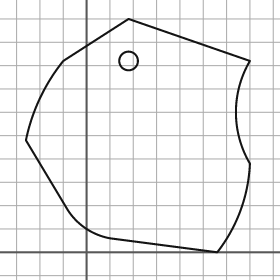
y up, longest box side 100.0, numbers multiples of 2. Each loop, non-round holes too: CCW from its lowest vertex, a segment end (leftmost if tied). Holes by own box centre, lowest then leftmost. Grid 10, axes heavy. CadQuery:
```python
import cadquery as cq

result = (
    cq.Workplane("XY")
    .moveTo(56.0, 0.0)
    .threePointArc((66.0, 18.0), (70.0, 38.0))
    .threePointArc((64.0, 60.0), (70.0, 82.0))
    .lineTo(18.0, 100.0)
    .lineTo(-10.0, 82.0)
    .threePointArc((-20.0, 66.0), (-26.0, 48.0))
    .lineTo(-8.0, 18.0)
    .threePointArc((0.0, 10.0), (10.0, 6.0))
    .close()
    .moveTo(18.0, 82.0)
    .circle(4.0)
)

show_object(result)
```